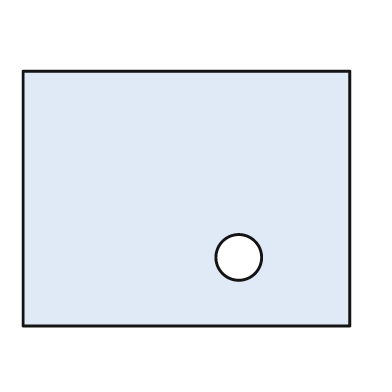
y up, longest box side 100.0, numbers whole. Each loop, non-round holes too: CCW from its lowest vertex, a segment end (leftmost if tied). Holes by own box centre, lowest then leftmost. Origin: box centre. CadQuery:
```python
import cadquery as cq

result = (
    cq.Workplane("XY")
    .moveTo(-50.0, -39.0)
    .lineTo(50.0, -39.0)
    .lineTo(50.0, 39.0)
    .lineTo(-50.0, 39.0)
    .close()
    .moveTo(16.0, -18.0)
    .circle(7.0)
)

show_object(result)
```